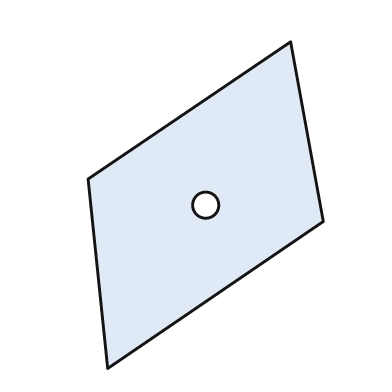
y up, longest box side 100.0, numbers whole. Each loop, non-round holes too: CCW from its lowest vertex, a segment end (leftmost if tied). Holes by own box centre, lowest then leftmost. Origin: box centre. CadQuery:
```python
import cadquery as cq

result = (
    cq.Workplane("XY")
    .moveTo(-30.0, -50.0)
    .lineTo(36.0, -5.0)
    .lineTo(26.0, 50.0)
    .lineTo(-36.0, 8.0)
    .close()
    .moveTo(0.0, 0.0)
    .circle(4.0)
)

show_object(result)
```